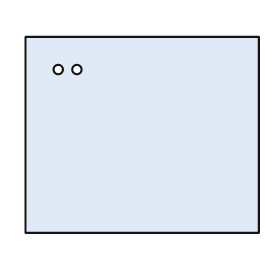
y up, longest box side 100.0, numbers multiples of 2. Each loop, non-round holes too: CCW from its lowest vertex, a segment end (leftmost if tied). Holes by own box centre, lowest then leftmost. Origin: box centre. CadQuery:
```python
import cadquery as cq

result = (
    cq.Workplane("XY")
    .moveTo(-50.0, -42.0)
    .lineTo(50.0, -42.0)
    .lineTo(50.0, 42.0)
    .lineTo(-50.0, 42.0)
    .close()
    .moveTo(-36.0, 28.0)
    .circle(2.0)
    .moveTo(-28.0, 28.0)
    .circle(2.0)
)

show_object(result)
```